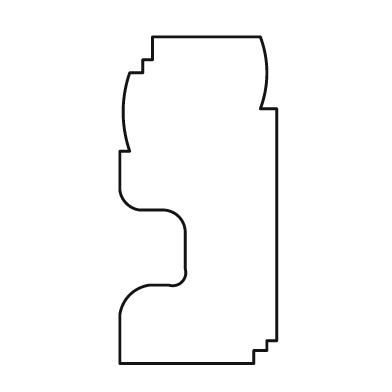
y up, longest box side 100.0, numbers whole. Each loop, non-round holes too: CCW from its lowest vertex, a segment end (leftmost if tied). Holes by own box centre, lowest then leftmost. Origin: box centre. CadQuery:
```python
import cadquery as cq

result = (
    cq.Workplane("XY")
    .moveTo(-24.0, -50.0)
    .lineTo(17.0, -50.0)
    .lineTo(17.0, -46.0)
    .lineTo(21.0, -46.0)
    .lineTo(21.0, -43.0)
    .lineTo(24.0, -43.0)
    .lineTo(24.0, 28.0)
    .lineTo(19.0, 28.0)
    .threePointArc((21.0, 39.0), (19.0, 50.0))
    .lineTo(-14.0, 50.0)
    .lineTo(-14.0, 43.0)
    .lineTo(-17.0, 43.0)
    .lineTo(-17.0, 39.0)
    .lineTo(-21.0, 39.0)
    .threePointArc((-23.0, 27.0), (-21.0, 15.0))
    .lineTo(-24.0, 15.0)
    .lineTo(-24.0, 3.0)
    .threePointArc((-22.0, -1.0), (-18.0, -3.0))
    .lineTo(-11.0, -3.0)
    .threePointArc((-6.0, -5.0), (-4.0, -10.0))
    .lineTo(-4.0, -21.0)
    .threePointArc((-5.0, -25.0), (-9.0, -26.0))
    .lineTo(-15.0, -26.0)
    .threePointArc((-21.0, -29.0), (-24.0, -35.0))
    .close()
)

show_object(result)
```